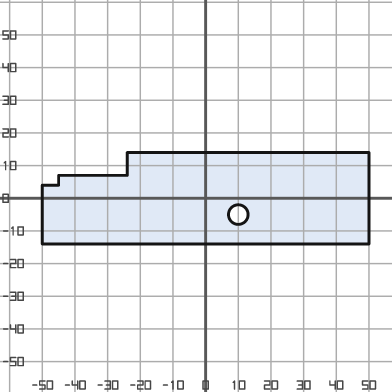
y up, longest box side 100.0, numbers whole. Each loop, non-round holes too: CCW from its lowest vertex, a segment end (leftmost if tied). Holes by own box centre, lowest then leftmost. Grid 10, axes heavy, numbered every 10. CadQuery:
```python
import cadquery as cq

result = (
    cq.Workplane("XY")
    .moveTo(-50.0, -14.0)
    .lineTo(50.0, -14.0)
    .lineTo(50.0, 14.0)
    .lineTo(-24.0, 14.0)
    .lineTo(-24.0, 7.0)
    .lineTo(-45.0, 7.0)
    .lineTo(-45.0, 4.0)
    .lineTo(-50.0, 4.0)
    .close()
    .moveTo(10.0, -5.0)
    .circle(3.0)
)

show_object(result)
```